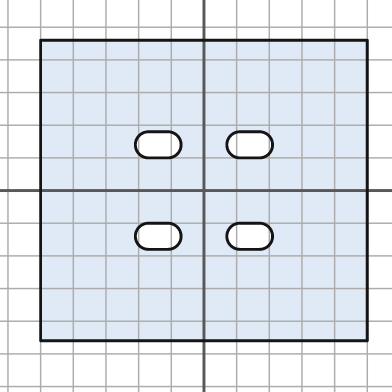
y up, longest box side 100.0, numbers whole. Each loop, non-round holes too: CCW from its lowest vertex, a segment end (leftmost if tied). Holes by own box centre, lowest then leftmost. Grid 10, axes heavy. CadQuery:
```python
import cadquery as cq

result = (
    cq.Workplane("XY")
    .moveTo(-50.0, -46.0)
    .lineTo(50.0, -46.0)
    .lineTo(50.0, 46.0)
    .lineTo(-50.0, 46.0)
    .close()
    .moveTo(-17.0, -18.0)
    .lineTo(-11.0, -18.0)
    .threePointArc((-7.0, -14.0), (-11.0, -10.0))
    .lineTo(-17.0, -10.0)
    .threePointArc((-21.0, -14.0), (-17.0, -18.0))
    .close()
    .moveTo(11.0, -18.0)
    .lineTo(17.0, -18.0)
    .threePointArc((21.0, -14.0), (17.0, -10.0))
    .lineTo(11.0, -10.0)
    .threePointArc((7.0, -14.0), (11.0, -18.0))
    .close()
    .moveTo(-17.0, 10.0)
    .lineTo(-11.0, 10.0)
    .threePointArc((-7.0, 14.0), (-11.0, 18.0))
    .lineTo(-17.0, 18.0)
    .threePointArc((-21.0, 14.0), (-17.0, 10.0))
    .close()
    .moveTo(11.0, 10.0)
    .lineTo(17.0, 10.0)
    .threePointArc((21.0, 14.0), (17.0, 18.0))
    .lineTo(11.0, 18.0)
    .threePointArc((7.0, 14.0), (11.0, 10.0))
    .close()
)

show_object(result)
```